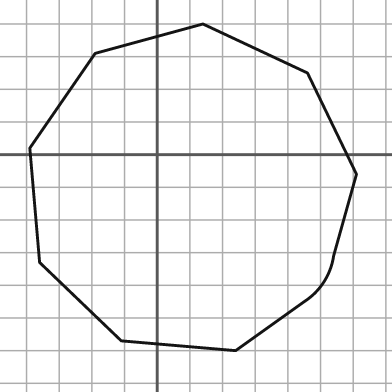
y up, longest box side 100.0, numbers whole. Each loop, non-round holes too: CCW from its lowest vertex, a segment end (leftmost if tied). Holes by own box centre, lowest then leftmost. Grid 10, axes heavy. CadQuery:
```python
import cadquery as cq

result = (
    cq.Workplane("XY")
    .moveTo(24.0, -60.0)
    .lineTo(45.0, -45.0)
    .threePointArc((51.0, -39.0), (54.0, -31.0))
    .lineTo(61.0, -6.0)
    .lineTo(46.0, 25.0)
    .lineTo(14.0, 40.0)
    .lineTo(-19.0, 31.0)
    .lineTo(-39.0, 2.0)
    .lineTo(-36.0, -33.0)
    .lineTo(-11.0, -57.0)
    .close()
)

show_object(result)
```